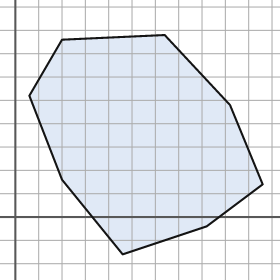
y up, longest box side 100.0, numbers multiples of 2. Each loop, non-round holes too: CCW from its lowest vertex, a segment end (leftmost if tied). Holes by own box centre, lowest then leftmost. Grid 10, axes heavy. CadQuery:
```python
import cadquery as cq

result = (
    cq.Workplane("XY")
    .moveTo(46.0, -16.0)
    .lineTo(82.0, -4.0)
    .lineTo(106.0, 14.0)
    .lineTo(92.0, 48.0)
    .lineTo(64.0, 78.0)
    .lineTo(20.0, 76.0)
    .lineTo(6.0, 52.0)
    .lineTo(20.0, 16.0)
    .close()
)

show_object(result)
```